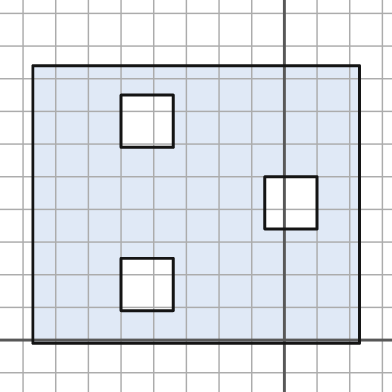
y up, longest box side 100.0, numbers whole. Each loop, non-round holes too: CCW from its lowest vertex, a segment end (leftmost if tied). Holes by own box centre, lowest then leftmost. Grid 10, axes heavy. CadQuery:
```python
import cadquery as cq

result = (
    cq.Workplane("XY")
    .moveTo(-77.0, -1.0)
    .lineTo(23.0, -1.0)
    .lineTo(23.0, 84.0)
    .lineTo(-77.0, 84.0)
    .close()
    .moveTo(-50.0, 9.0)
    .lineTo(-34.0, 9.0)
    .lineTo(-34.0, 25.0)
    .lineTo(-50.0, 25.0)
    .close()
    .moveTo(-6.0, 34.0)
    .lineTo(10.0, 34.0)
    .lineTo(10.0, 50.0)
    .lineTo(-6.0, 50.0)
    .close()
    .moveTo(-50.0, 59.0)
    .lineTo(-34.0, 59.0)
    .lineTo(-34.0, 75.0)
    .lineTo(-50.0, 75.0)
    .close()
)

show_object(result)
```